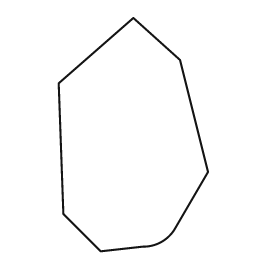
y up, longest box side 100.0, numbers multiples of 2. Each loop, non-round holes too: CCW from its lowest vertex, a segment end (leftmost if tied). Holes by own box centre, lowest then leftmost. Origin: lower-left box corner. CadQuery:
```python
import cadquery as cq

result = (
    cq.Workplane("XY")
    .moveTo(18.0, 0.0)
    .lineTo(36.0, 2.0)
    .threePointArc((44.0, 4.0), (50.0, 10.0))
    .lineTo(64.0, 34.0)
    .lineTo(52.0, 82.0)
    .lineTo(32.0, 100.0)
    .lineTo(0.0, 72.0)
    .lineTo(2.0, 16.0)
    .close()
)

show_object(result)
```